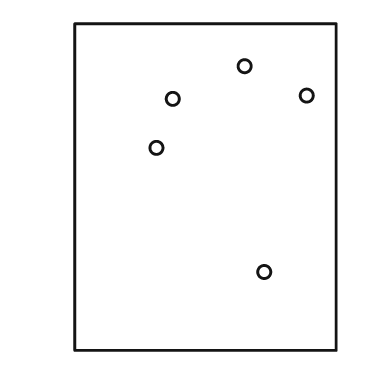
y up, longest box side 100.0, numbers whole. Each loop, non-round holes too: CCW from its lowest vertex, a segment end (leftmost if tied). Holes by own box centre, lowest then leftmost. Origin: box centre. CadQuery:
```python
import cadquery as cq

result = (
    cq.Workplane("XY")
    .moveTo(-40.0, -50.0)
    .lineTo(40.0, -50.0)
    .lineTo(40.0, 50.0)
    .lineTo(-40.0, 50.0)
    .close()
    .moveTo(18.0, -26.0)
    .circle(2.0)
    .moveTo(-15.0, 12.0)
    .circle(2.0)
    .moveTo(-10.0, 27.0)
    .circle(2.0)
    .moveTo(31.0, 28.0)
    .circle(2.0)
    .moveTo(12.0, 37.0)
    .circle(2.0)
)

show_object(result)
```